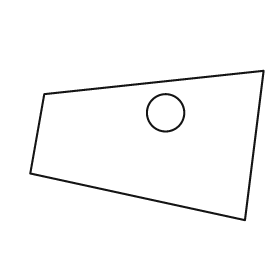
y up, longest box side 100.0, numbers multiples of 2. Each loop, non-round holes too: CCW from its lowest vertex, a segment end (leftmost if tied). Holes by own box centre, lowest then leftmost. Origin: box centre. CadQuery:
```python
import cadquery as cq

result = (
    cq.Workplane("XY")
    .moveTo(42.0, -32.0)
    .lineTo(50.0, 32.0)
    .lineTo(-44.0, 22.0)
    .lineTo(-50.0, -12.0)
    .close()
    .moveTo(8.0, 14.0)
    .circle(8.0)
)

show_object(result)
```